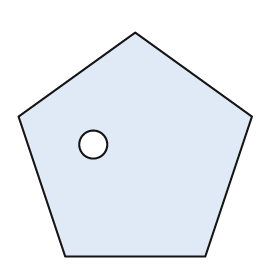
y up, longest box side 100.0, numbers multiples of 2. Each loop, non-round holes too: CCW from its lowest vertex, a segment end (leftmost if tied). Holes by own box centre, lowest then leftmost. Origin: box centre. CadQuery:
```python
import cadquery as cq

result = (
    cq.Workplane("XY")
    .moveTo(-30.0, -48.0)
    .lineTo(30.0, -48.0)
    .lineTo(50.0, 12.0)
    .lineTo(0.0, 48.0)
    .lineTo(-50.0, 12.0)
    .close()
    .moveTo(-18.0, 0.0)
    .circle(6.0)
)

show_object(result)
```